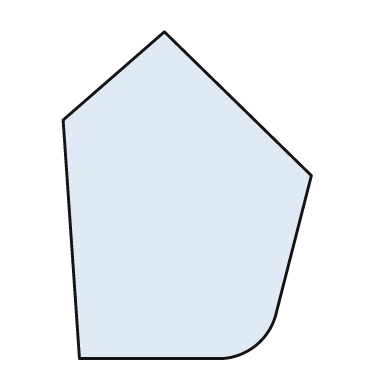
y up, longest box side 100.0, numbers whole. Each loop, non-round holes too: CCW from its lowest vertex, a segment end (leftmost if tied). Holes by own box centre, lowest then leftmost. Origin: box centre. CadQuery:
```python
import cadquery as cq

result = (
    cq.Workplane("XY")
    .moveTo(-33.0, -50.0)
    .lineTo(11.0, -50.0)
    .threePointArc((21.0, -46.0), (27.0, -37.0))
    .lineTo(38.0, 6.0)
    .lineTo(-7.0, 50.0)
    .lineTo(-38.0, 23.0)
    .close()
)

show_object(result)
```